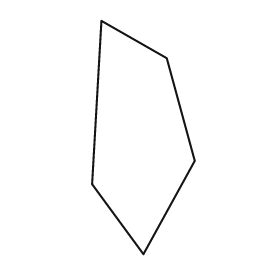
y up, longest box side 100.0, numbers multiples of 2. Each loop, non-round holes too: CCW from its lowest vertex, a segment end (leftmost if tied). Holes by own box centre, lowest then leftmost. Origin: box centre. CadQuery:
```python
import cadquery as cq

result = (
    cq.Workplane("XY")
    .moveTo(0.0, -50.0)
    .lineTo(22.0, -10.0)
    .lineTo(10.0, 34.0)
    .lineTo(-18.0, 50.0)
    .lineTo(-22.0, -20.0)
    .close()
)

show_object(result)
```